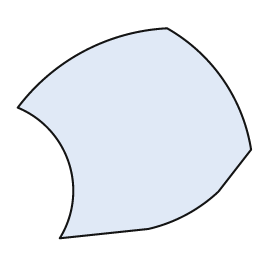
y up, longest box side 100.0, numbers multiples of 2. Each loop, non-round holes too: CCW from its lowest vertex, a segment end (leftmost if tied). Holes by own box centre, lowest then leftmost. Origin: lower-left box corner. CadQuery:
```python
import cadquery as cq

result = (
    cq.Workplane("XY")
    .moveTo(18.0, 0.0)
    .lineTo(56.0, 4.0)
    .threePointArc((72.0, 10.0), (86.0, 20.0))
    .lineTo(100.0, 38.0)
    .threePointArc((88.0, 68.0), (64.0, 90.0))
    .threePointArc((28.0, 80.0), (0.0, 56.0))
    .threePointArc((22.0, 32.0), (18.0, 0.0))
    .close()
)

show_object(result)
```